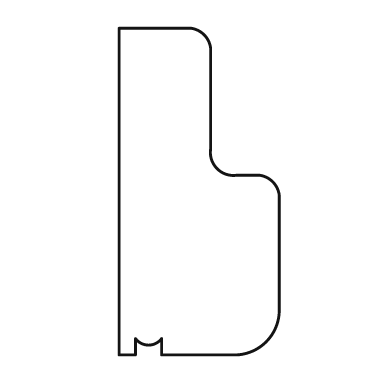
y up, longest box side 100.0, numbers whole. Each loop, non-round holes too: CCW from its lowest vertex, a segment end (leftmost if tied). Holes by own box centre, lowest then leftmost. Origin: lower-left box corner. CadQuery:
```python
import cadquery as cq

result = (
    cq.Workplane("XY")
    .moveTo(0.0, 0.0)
    .lineTo(5.0, 0.0)
    .lineTo(5.0, 5.0)
    .threePointArc((9.0, 3.0), (13.0, 5.0))
    .lineTo(13.0, 0.0)
    .lineTo(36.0, 0.0)
    .threePointArc((45.0, 4.0), (49.0, 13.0))
    .lineTo(49.0, 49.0)
    .threePointArc((47.0, 53.0), (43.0, 55.0))
    .lineTo(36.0, 55.0)
    .threePointArc((30.0, 57.0), (28.0, 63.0))
    .lineTo(28.0, 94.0)
    .threePointArc((26.0, 98.0), (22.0, 100.0))
    .lineTo(0.0, 100.0)
    .close()
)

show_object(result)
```